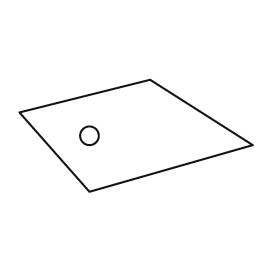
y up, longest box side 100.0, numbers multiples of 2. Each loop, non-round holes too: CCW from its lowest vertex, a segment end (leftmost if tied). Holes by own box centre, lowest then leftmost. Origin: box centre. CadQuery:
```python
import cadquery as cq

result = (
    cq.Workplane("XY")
    .moveTo(-20.0, -24.0)
    .lineTo(50.0, -4.0)
    .lineTo(6.0, 24.0)
    .lineTo(-50.0, 10.0)
    .close()
    .moveTo(-20.0, 0.0)
    .circle(4.0)
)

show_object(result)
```